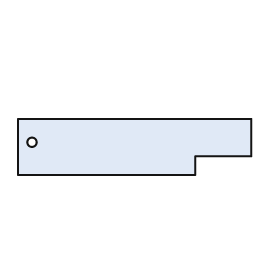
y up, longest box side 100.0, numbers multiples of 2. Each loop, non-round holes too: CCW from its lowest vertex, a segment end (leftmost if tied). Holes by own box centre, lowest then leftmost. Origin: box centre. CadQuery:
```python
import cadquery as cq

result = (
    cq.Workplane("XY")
    .moveTo(-50.0, -12.0)
    .lineTo(26.0, -12.0)
    .lineTo(26.0, -4.0)
    .lineTo(50.0, -4.0)
    .lineTo(50.0, 12.0)
    .lineTo(-50.0, 12.0)
    .close()
    .moveTo(-44.0, 2.0)
    .circle(2.0)
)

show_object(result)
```